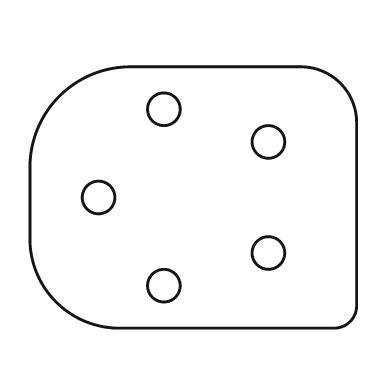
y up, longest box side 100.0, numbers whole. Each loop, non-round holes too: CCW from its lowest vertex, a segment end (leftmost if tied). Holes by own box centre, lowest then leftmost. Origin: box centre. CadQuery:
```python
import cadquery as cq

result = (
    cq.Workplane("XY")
    .moveTo(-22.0, -40.0)
    .lineTo(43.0, -40.0)
    .threePointArc((48.0, -38.0), (50.0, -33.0))
    .lineTo(50.0, 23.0)
    .threePointArc((45.0, 35.0), (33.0, 40.0))
    .lineTo(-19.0, 40.0)
    .threePointArc((-41.0, 31.0), (-50.0, 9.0))
    .lineTo(-50.0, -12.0)
    .threePointArc((-42.0, -32.0), (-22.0, -40.0))
    .close()
    .moveTo(-9.0, -27.0)
    .circle(5.0)
    .moveTo(23.0, -17.0)
    .circle(5.0)
    .moveTo(-29.0, 0.0)
    .circle(5.0)
    .moveTo(23.0, 17.0)
    .circle(5.0)
    .moveTo(-9.0, 27.0)
    .circle(5.0)
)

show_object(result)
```